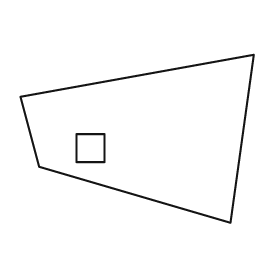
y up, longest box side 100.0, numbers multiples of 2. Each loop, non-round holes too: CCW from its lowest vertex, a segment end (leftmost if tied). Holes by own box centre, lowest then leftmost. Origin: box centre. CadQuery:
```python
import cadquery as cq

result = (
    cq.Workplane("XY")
    .moveTo(40.0, -36.0)
    .lineTo(50.0, 36.0)
    .lineTo(-50.0, 18.0)
    .lineTo(-42.0, -12.0)
    .close()
    .moveTo(-26.0, -10.0)
    .lineTo(-14.0, -10.0)
    .lineTo(-14.0, 2.0)
    .lineTo(-26.0, 2.0)
    .close()
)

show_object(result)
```